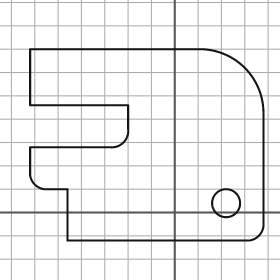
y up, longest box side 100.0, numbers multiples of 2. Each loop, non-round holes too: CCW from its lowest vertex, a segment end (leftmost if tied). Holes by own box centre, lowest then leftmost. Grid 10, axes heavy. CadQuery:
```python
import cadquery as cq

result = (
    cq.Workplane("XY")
    .moveTo(-46.0, -12.0)
    .lineTo(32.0, -12.0)
    .threePointArc((36.0, -10.0), (38.0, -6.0))
    .lineTo(38.0, 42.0)
    .threePointArc((30.0, 62.0), (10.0, 70.0))
    .lineTo(-62.0, 70.0)
    .lineTo(-62.0, 46.0)
    .lineTo(-20.0, 46.0)
    .lineTo(-20.0, 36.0)
    .threePointArc((-22.0, 30.0), (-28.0, 28.0))
    .lineTo(-62.0, 28.0)
    .lineTo(-62.0, 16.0)
    .threePointArc((-60.0, 12.0), (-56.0, 10.0))
    .lineTo(-46.0, 10.0)
    .close()
    .moveTo(22.0, 4.0)
    .circle(6.0)
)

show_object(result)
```